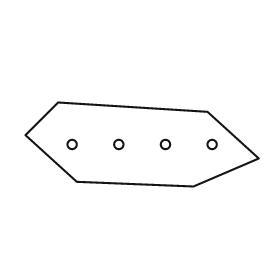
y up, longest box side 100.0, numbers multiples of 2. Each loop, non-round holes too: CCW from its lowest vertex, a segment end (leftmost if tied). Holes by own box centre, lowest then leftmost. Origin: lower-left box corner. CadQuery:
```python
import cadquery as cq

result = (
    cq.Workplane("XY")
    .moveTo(72.0, 0.0)
    .lineTo(100.0, 12.0)
    .lineTo(78.0, 32.0)
    .lineTo(14.0, 36.0)
    .lineTo(0.0, 22.0)
    .lineTo(22.0, 2.0)
    .close()
    .moveTo(20.0, 18.0)
    .circle(2.0)
    .moveTo(40.0, 18.0)
    .circle(2.0)
    .moveTo(60.0, 18.0)
    .circle(2.0)
    .moveTo(80.0, 18.0)
    .circle(2.0)
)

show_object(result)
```